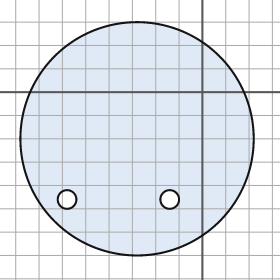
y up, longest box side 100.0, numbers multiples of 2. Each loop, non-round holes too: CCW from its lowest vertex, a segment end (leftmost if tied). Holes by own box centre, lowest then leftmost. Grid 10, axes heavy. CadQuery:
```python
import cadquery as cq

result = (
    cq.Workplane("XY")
    .moveTo(-28.0, -20.0)
    .circle(50.0)
    .moveTo(-58.0, -46.0)
    .circle(4.0)
    .moveTo(-14.0, -46.0)
    .circle(4.0)
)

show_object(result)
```